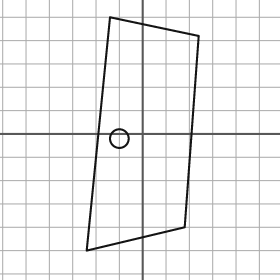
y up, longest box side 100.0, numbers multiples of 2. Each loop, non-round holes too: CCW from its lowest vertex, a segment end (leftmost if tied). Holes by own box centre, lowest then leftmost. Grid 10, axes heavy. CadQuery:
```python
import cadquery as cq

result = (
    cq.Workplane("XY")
    .moveTo(-24.0, -50.0)
    .lineTo(18.0, -40.0)
    .lineTo(24.0, 42.0)
    .lineTo(-14.0, 50.0)
    .close()
    .moveTo(-10.0, -2.0)
    .circle(4.0)
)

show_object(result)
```